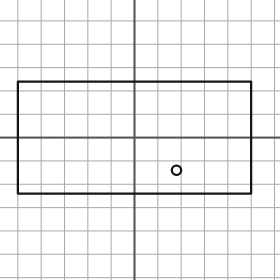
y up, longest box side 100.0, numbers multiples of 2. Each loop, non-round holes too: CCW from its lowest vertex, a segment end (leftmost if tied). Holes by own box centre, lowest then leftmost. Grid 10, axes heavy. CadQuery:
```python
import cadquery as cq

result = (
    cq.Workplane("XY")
    .moveTo(-50.0, -24.0)
    .lineTo(50.0, -24.0)
    .lineTo(50.0, 24.0)
    .lineTo(-50.0, 24.0)
    .close()
    .moveTo(18.0, -14.0)
    .circle(2.0)
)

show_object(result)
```